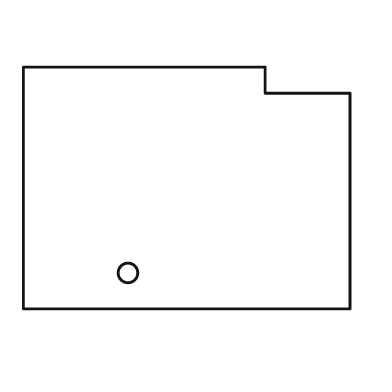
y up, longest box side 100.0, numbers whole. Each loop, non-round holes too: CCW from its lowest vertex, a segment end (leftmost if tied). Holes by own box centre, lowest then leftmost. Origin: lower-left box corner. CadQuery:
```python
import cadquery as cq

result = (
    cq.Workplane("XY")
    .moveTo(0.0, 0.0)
    .lineTo(100.0, 0.0)
    .lineTo(100.0, 66.0)
    .lineTo(74.0, 66.0)
    .lineTo(74.0, 74.0)
    .lineTo(0.0, 74.0)
    .close()
    .moveTo(32.0, 11.0)
    .circle(3.0)
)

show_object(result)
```